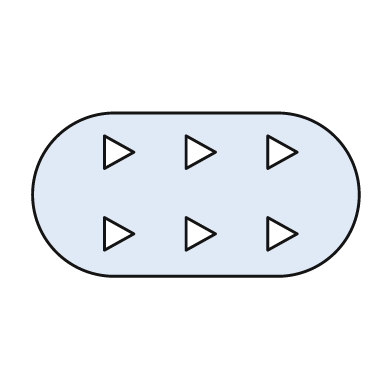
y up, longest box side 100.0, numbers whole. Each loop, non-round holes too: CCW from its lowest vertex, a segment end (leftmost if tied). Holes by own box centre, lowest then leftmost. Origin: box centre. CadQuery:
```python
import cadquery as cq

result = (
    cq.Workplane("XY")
    .moveTo(-25.0, -25.0)
    .lineTo(25.0, -25.0)
    .threePointArc((50.0, 0.0), (25.0, 25.0))
    .lineTo(-25.0, 25.0)
    .threePointArc((-50.0, 0.0), (-25.0, -25.0))
    .close()
    .moveTo(-28.0, -17.0)
    .lineTo(-19.0, -12.0)
    .lineTo(-28.0, -7.0)
    .close()
    .moveTo(-3.0, -17.0)
    .lineTo(6.0, -12.0)
    .lineTo(-3.0, -7.0)
    .close()
    .moveTo(22.0, -17.0)
    .lineTo(31.0, -12.0)
    .lineTo(22.0, -7.0)
    .close()
    .moveTo(-28.0, 8.0)
    .lineTo(-19.0, 13.0)
    .lineTo(-28.0, 18.0)
    .close()
    .moveTo(-3.0, 8.0)
    .lineTo(6.0, 13.0)
    .lineTo(-3.0, 18.0)
    .close()
    .moveTo(22.0, 8.0)
    .lineTo(31.0, 13.0)
    .lineTo(22.0, 18.0)
    .close()
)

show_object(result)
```